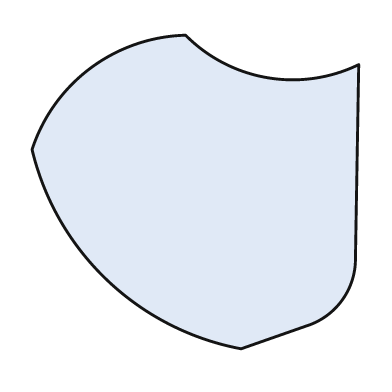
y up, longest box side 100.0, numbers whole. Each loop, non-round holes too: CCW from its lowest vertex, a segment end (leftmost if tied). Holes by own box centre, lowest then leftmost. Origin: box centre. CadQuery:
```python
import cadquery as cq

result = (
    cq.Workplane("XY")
    .moveTo(14.0, -48.0)
    .lineTo(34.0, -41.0)
    .threePointArc((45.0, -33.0), (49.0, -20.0))
    .lineTo(50.0, 39.0)
    .threePointArc((22.0, 35.0), (-3.0, 48.0))
    .threePointArc((-32.0, 38.0), (-50.0, 13.0))
    .threePointArc((-27.0, -27.0), (14.0, -48.0))
    .close()
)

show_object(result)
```